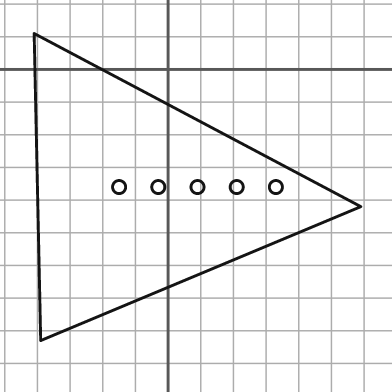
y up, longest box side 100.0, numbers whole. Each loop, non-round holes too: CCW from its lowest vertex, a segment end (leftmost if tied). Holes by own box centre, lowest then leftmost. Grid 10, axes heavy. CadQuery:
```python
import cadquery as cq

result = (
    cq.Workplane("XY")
    .moveTo(-39.0, -83.0)
    .lineTo(59.0, -42.0)
    .lineTo(-41.0, 11.0)
    .close()
    .moveTo(-15.0, -36.0)
    .circle(2.0)
    .moveTo(-3.0, -36.0)
    .circle(2.0)
    .moveTo(9.0, -36.0)
    .circle(2.0)
    .moveTo(21.0, -36.0)
    .circle(2.0)
    .moveTo(33.0, -36.0)
    .circle(2.0)
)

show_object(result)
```